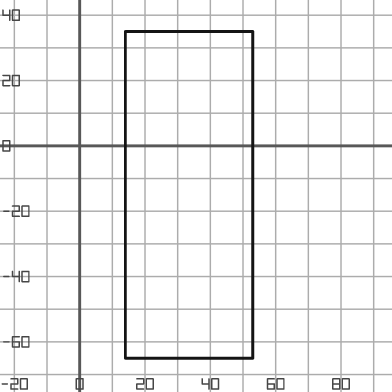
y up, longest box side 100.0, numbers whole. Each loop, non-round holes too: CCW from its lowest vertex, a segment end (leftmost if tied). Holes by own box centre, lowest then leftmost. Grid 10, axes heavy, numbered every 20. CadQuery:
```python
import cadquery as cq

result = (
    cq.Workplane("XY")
    .moveTo(14.0, -65.0)
    .lineTo(53.0, -65.0)
    .lineTo(53.0, 35.0)
    .lineTo(14.0, 35.0)
    .close()
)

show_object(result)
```